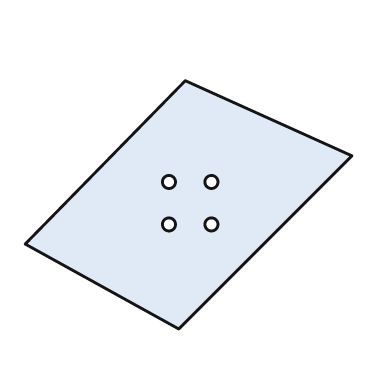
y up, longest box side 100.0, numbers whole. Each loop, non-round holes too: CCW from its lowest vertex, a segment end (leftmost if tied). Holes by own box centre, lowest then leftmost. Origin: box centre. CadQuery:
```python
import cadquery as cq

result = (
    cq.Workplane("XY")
    .moveTo(-3.0, -38.0)
    .lineTo(50.0, 15.0)
    .lineTo(-1.0, 38.0)
    .lineTo(-50.0, -12.0)
    .close()
    .moveTo(-6.0, -6.0)
    .circle(2.0)
    .moveTo(7.0, -6.0)
    .circle(2.0)
    .moveTo(-6.0, 7.0)
    .circle(2.0)
    .moveTo(7.0, 7.0)
    .circle(2.0)
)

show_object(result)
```